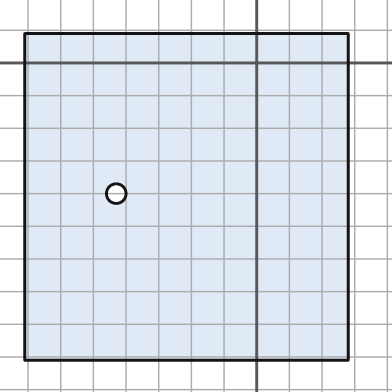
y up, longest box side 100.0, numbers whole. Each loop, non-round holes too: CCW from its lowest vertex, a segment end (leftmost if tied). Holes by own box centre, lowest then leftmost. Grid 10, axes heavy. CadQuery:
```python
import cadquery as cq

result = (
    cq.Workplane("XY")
    .moveTo(-71.0, -91.0)
    .lineTo(28.0, -91.0)
    .lineTo(28.0, 9.0)
    .lineTo(-71.0, 9.0)
    .close()
    .moveTo(-43.0, -40.0)
    .circle(3.0)
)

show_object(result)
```